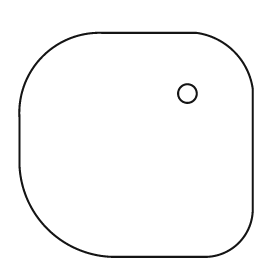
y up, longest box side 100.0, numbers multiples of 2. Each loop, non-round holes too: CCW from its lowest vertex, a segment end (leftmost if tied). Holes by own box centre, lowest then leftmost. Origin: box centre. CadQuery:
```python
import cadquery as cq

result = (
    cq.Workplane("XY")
    .moveTo(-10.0, -48.0)
    .lineTo(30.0, -48.0)
    .threePointArc((44.0, -42.0), (50.0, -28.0))
    .lineTo(50.0, 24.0)
    .threePointArc((42.0, 40.0), (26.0, 48.0))
    .lineTo(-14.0, 48.0)
    .threePointArc((-40.0, 38.0), (-50.0, 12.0))
    .lineTo(-50.0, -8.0)
    .threePointArc((-38.0, -36.0), (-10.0, -48.0))
    .close()
    .moveTo(22.0, 22.0)
    .circle(4.0)
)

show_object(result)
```